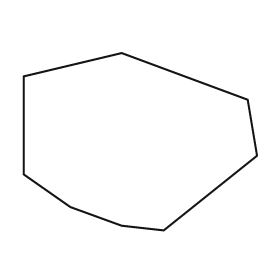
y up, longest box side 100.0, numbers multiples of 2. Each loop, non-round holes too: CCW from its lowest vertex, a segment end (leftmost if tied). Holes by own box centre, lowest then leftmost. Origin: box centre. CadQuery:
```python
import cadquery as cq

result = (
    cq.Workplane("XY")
    .moveTo(10.0, -38.0)
    .lineTo(50.0, -6.0)
    .lineTo(46.0, 18.0)
    .lineTo(-8.0, 38.0)
    .lineTo(-50.0, 28.0)
    .lineTo(-50.0, -14.0)
    .lineTo(-30.0, -28.0)
    .lineTo(-8.0, -36.0)
    .close()
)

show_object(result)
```